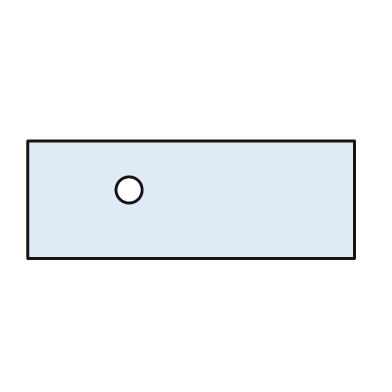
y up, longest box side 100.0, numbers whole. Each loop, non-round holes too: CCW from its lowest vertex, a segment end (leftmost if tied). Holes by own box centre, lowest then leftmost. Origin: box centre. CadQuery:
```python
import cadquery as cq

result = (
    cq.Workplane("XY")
    .moveTo(-50.0, -18.0)
    .lineTo(50.0, -18.0)
    .lineTo(50.0, 18.0)
    .lineTo(-50.0, 18.0)
    .close()
    .moveTo(-19.0, 3.0)
    .circle(4.0)
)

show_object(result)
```